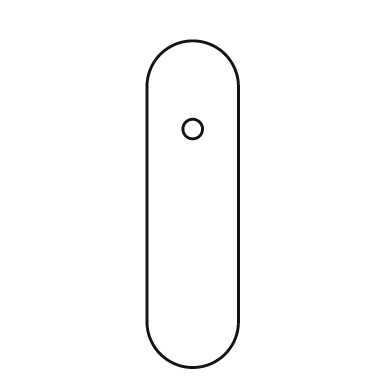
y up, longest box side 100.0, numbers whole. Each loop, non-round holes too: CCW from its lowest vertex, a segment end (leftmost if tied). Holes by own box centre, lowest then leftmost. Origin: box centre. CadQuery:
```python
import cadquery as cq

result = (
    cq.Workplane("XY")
    .moveTo(-14.0, -36.0)
    .threePointArc((0.0, -50.0), (14.0, -36.0))
    .lineTo(14.0, 36.0)
    .threePointArc((0.0, 50.0), (-14.0, 36.0))
    .close()
    .moveTo(0.0, 23.0)
    .circle(3.0)
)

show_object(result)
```